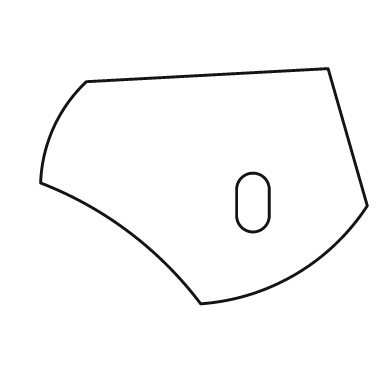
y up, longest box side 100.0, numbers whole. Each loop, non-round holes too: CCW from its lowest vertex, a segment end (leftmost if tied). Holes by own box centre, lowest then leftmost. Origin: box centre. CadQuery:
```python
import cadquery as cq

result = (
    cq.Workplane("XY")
    .moveTo(-1.0, -36.0)
    .threePointArc((28.0, -27.0), (50.0, -6.0))
    .lineTo(38.0, 36.0)
    .lineTo(-36.0, 32.0)
    .threePointArc((-46.0, 18.0), (-50.0, 1.0))
    .threePointArc((-23.0, -14.0), (-1.0, -36.0))
    .close()
    .moveTo(10.0, -9.0)
    .threePointArc((15.0, -14.0), (20.0, -9.0))
    .lineTo(20.0, -1.0)
    .threePointArc((15.0, 4.0), (10.0, -1.0))
    .close()
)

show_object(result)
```